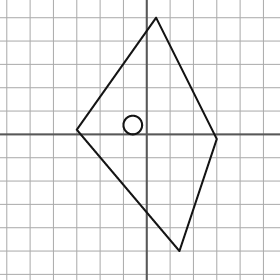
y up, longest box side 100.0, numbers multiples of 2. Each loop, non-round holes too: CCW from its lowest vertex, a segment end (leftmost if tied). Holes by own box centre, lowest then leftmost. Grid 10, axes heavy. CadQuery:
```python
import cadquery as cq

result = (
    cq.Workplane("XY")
    .moveTo(14.0, -50.0)
    .lineTo(30.0, -2.0)
    .lineTo(4.0, 50.0)
    .lineTo(-30.0, 2.0)
    .close()
    .moveTo(-6.0, 4.0)
    .circle(4.0)
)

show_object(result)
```